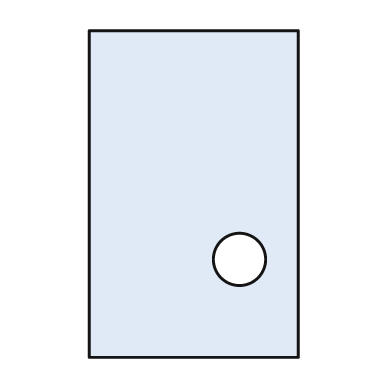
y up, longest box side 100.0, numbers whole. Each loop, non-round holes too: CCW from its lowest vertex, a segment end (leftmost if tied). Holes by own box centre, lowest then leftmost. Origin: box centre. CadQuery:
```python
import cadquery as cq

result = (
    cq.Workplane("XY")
    .moveTo(-32.0, -50.0)
    .lineTo(32.0, -50.0)
    .lineTo(32.0, 50.0)
    .lineTo(-32.0, 50.0)
    .close()
    .moveTo(14.0, -20.0)
    .circle(8.0)
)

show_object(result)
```